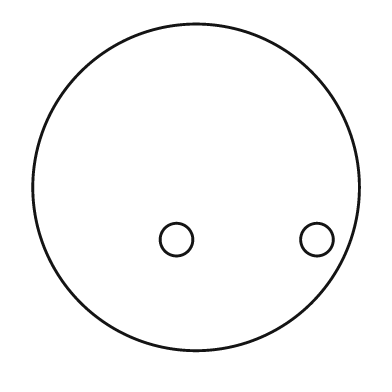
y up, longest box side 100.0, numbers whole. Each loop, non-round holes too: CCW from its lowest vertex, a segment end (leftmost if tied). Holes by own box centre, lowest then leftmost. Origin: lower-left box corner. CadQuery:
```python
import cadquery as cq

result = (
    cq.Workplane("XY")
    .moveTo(50.0, 50.0)
    .circle(50.0)
    .moveTo(44.0, 34.0)
    .circle(5.0)
    .moveTo(87.0, 34.0)
    .circle(5.0)
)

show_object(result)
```